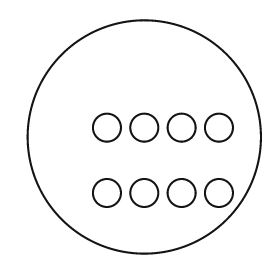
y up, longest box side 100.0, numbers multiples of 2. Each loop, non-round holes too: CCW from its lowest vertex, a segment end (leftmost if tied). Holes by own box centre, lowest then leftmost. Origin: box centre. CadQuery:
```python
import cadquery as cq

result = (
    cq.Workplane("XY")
    .moveTo(0.0, 0.0)
    .circle(50.0)
    .moveTo(-16.0, -24.0)
    .circle(6.0)
    .moveTo(0.0, -24.0)
    .circle(6.0)
    .moveTo(16.0, -24.0)
    .circle(6.0)
    .moveTo(32.0, -24.0)
    .circle(6.0)
    .moveTo(-16.0, 4.0)
    .circle(6.0)
    .moveTo(0.0, 4.0)
    .circle(6.0)
    .moveTo(16.0, 4.0)
    .circle(6.0)
    .moveTo(32.0, 4.0)
    .circle(6.0)
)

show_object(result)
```